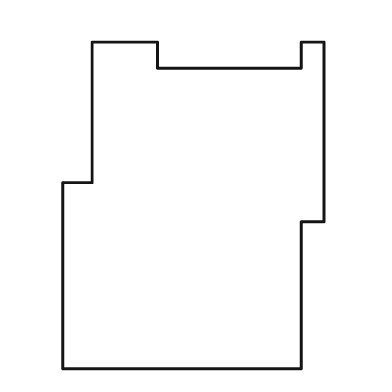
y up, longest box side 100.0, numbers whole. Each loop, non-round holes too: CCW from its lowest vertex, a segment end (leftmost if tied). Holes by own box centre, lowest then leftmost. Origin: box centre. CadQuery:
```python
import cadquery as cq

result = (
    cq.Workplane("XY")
    .moveTo(-40.0, -50.0)
    .lineTo(33.0, -50.0)
    .lineTo(33.0, -5.0)
    .lineTo(40.0, -5.0)
    .lineTo(40.0, 50.0)
    .lineTo(33.0, 50.0)
    .lineTo(33.0, 42.0)
    .lineTo(-11.0, 42.0)
    .lineTo(-11.0, 50.0)
    .lineTo(-31.0, 50.0)
    .lineTo(-31.0, 7.0)
    .lineTo(-40.0, 7.0)
    .close()
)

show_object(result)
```